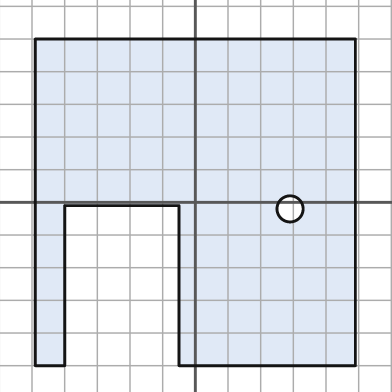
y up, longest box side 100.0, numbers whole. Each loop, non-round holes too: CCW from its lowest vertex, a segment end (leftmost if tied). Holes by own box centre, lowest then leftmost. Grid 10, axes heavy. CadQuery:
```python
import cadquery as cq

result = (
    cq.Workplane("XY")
    .moveTo(-49.0, -50.0)
    .lineTo(-40.0, -50.0)
    .lineTo(-40.0, -1.0)
    .lineTo(-5.0, -1.0)
    .lineTo(-5.0, -50.0)
    .lineTo(49.0, -50.0)
    .lineTo(49.0, 50.0)
    .lineTo(-49.0, 50.0)
    .close()
    .moveTo(29.0, -2.0)
    .circle(4.0)
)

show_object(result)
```